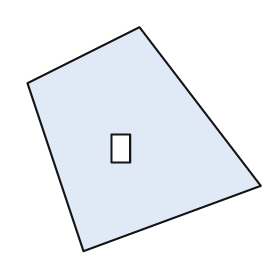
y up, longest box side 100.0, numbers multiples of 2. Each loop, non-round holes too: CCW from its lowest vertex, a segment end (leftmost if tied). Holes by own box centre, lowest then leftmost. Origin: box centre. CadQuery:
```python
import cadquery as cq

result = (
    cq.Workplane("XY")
    .moveTo(-26.0, -48.0)
    .lineTo(50.0, -20.0)
    .lineTo(-2.0, 48.0)
    .lineTo(-50.0, 24.0)
    .close()
    .moveTo(-14.0, -10.0)
    .lineTo(-6.0, -10.0)
    .lineTo(-6.0, 2.0)
    .lineTo(-14.0, 2.0)
    .close()
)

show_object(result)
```